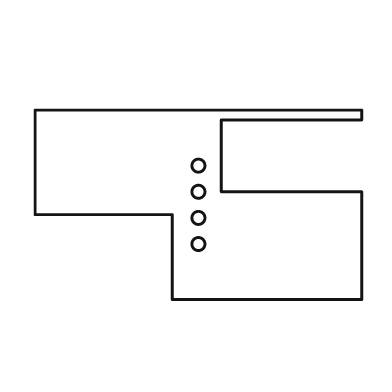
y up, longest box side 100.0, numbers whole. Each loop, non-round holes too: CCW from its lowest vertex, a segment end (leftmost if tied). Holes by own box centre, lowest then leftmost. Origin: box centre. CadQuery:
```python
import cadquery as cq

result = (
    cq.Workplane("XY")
    .moveTo(-8.0, -29.0)
    .lineTo(50.0, -29.0)
    .lineTo(50.0, 4.0)
    .lineTo(7.0, 4.0)
    .lineTo(7.0, 26.0)
    .lineTo(50.0, 26.0)
    .lineTo(50.0, 29.0)
    .lineTo(-50.0, 29.0)
    .lineTo(-50.0, -3.0)
    .lineTo(-8.0, -3.0)
    .close()
    .moveTo(0.0, -12.0)
    .circle(2.0)
    .moveTo(0.0, -4.0)
    .circle(2.0)
    .moveTo(0.0, 4.0)
    .circle(2.0)
    .moveTo(0.0, 12.0)
    .circle(2.0)
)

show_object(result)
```